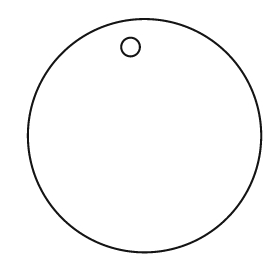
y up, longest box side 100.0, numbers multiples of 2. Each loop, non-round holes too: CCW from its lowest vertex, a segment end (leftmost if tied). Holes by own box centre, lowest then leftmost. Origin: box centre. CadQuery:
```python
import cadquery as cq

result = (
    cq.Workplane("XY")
    .moveTo(0.0, 0.0)
    .circle(50.0)
    .moveTo(-6.0, 38.0)
    .circle(4.0)
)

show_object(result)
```